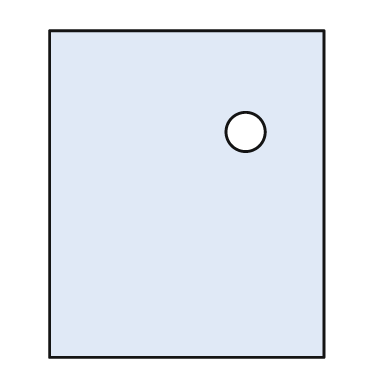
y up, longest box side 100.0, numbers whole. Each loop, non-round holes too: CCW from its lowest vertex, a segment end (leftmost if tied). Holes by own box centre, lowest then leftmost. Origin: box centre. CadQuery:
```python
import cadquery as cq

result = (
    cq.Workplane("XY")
    .moveTo(-42.0, -50.0)
    .lineTo(42.0, -50.0)
    .lineTo(42.0, 50.0)
    .lineTo(-42.0, 50.0)
    .close()
    .moveTo(18.0, 19.0)
    .circle(6.0)
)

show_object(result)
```